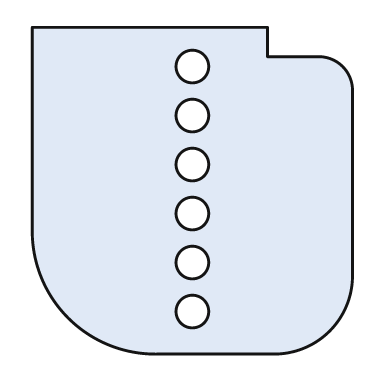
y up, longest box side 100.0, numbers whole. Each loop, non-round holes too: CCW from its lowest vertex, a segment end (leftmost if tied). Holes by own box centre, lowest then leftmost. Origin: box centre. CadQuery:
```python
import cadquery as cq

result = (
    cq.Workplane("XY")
    .moveTo(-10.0, -50.0)
    .lineTo(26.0, -50.0)
    .threePointArc((42.0, -43.0), (49.0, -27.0))
    .lineTo(49.0, 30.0)
    .threePointArc((46.0, 38.0), (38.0, 41.0))
    .lineTo(23.0, 41.0)
    .lineTo(23.0, 50.0)
    .lineTo(-49.0, 50.0)
    .lineTo(-49.0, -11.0)
    .threePointArc((-38.0, -39.0), (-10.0, -50.0))
    .close()
    .moveTo(0.0, -37.0)
    .circle(5.0)
    .moveTo(0.0, -22.0)
    .circle(5.0)
    .moveTo(0.0, -7.0)
    .circle(5.0)
    .moveTo(0.0, 8.0)
    .circle(5.0)
    .moveTo(0.0, 23.0)
    .circle(5.0)
    .moveTo(0.0, 38.0)
    .circle(5.0)
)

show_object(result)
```